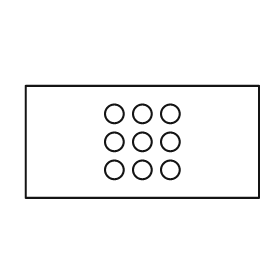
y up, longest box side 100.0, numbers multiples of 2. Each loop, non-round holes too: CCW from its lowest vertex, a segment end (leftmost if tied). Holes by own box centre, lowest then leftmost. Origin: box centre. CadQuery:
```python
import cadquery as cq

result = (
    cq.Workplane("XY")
    .moveTo(-50.0, -24.0)
    .lineTo(50.0, -24.0)
    .lineTo(50.0, 24.0)
    .lineTo(-50.0, 24.0)
    .close()
    .moveTo(-12.0, -12.0)
    .circle(4.0)
    .moveTo(0.0, -12.0)
    .circle(4.0)
    .moveTo(12.0, -12.0)
    .circle(4.0)
    .moveTo(-12.0, 0.0)
    .circle(4.0)
    .moveTo(0.0, 0.0)
    .circle(4.0)
    .moveTo(12.0, 0.0)
    .circle(4.0)
    .moveTo(-12.0, 12.0)
    .circle(4.0)
    .moveTo(0.0, 12.0)
    .circle(4.0)
    .moveTo(12.0, 12.0)
    .circle(4.0)
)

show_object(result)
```